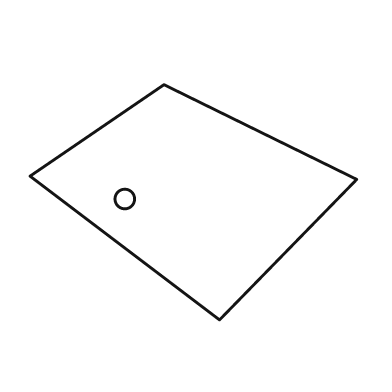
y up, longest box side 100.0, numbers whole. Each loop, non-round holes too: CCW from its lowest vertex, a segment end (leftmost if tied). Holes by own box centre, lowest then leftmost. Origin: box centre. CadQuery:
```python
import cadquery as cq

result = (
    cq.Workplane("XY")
    .moveTo(8.0, -36.0)
    .lineTo(50.0, 7.0)
    .lineTo(-9.0, 36.0)
    .lineTo(-50.0, 8.0)
    .close()
    .moveTo(-21.0, 1.0)
    .circle(3.0)
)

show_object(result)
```